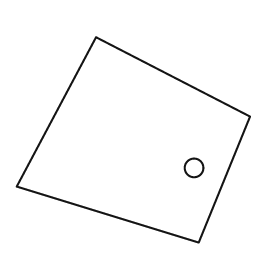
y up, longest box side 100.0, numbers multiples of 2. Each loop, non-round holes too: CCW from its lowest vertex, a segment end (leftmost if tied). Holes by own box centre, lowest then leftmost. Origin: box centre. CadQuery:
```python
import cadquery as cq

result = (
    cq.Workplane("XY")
    .moveTo(28.0, -44.0)
    .lineTo(50.0, 10.0)
    .lineTo(-16.0, 44.0)
    .lineTo(-50.0, -20.0)
    .close()
    .moveTo(26.0, -12.0)
    .circle(4.0)
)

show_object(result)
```